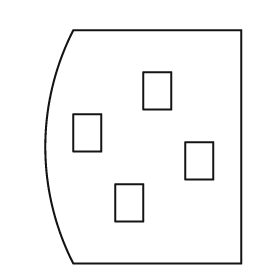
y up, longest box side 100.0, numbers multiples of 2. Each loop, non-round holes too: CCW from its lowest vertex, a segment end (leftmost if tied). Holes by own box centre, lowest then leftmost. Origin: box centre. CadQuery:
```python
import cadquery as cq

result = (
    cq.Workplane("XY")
    .moveTo(-30.0, -50.0)
    .lineTo(42.0, -50.0)
    .lineTo(42.0, 50.0)
    .lineTo(-30.0, 50.0)
    .threePointArc((-42.0, 0.0), (-30.0, -50.0))
    .close()
    .moveTo(-12.0, -32.0)
    .lineTo(0.0, -32.0)
    .lineTo(0.0, -16.0)
    .lineTo(-12.0, -16.0)
    .close()
    .moveTo(18.0, -14.0)
    .lineTo(30.0, -14.0)
    .lineTo(30.0, 2.0)
    .lineTo(18.0, 2.0)
    .close()
    .moveTo(-30.0, -2.0)
    .lineTo(-18.0, -2.0)
    .lineTo(-18.0, 14.0)
    .lineTo(-30.0, 14.0)
    .close()
    .moveTo(0.0, 16.0)
    .lineTo(12.0, 16.0)
    .lineTo(12.0, 32.0)
    .lineTo(0.0, 32.0)
    .close()
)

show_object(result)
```